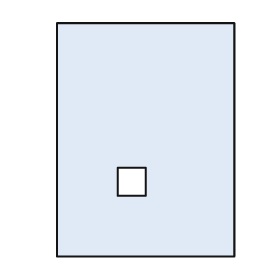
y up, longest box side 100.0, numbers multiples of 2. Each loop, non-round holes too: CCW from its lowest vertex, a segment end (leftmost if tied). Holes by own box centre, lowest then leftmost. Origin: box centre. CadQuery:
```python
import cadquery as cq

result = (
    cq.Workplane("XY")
    .moveTo(-38.0, -50.0)
    .lineTo(38.0, -50.0)
    .lineTo(38.0, 50.0)
    .lineTo(-38.0, 50.0)
    .close()
    .moveTo(-12.0, -24.0)
    .lineTo(0.0, -24.0)
    .lineTo(0.0, -12.0)
    .lineTo(-12.0, -12.0)
    .close()
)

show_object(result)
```